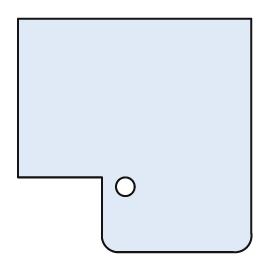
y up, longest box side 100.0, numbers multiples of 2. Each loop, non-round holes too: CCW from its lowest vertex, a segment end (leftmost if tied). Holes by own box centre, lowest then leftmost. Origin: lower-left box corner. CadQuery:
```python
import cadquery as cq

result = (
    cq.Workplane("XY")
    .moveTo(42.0, 0.0)
    .lineTo(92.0, 0.0)
    .threePointArc((98.0, 2.0), (100.0, 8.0))
    .lineTo(100.0, 100.0)
    .lineTo(0.0, 100.0)
    .lineTo(0.0, 32.0)
    .lineTo(36.0, 32.0)
    .lineTo(36.0, 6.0)
    .threePointArc((38.0, 2.0), (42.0, 0.0))
    .close()
    .moveTo(46.0, 28.0)
    .circle(4.0)
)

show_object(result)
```